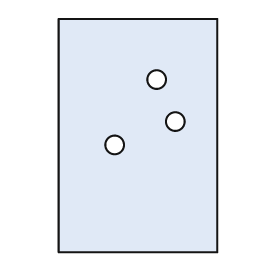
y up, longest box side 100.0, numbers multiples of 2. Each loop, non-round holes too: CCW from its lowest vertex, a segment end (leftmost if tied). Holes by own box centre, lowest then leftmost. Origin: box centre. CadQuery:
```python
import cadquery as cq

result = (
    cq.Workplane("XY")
    .moveTo(-34.0, -50.0)
    .lineTo(34.0, -50.0)
    .lineTo(34.0, 50.0)
    .lineTo(-34.0, 50.0)
    .close()
    .moveTo(-10.0, -4.0)
    .circle(4.0)
    .moveTo(16.0, 6.0)
    .circle(4.0)
    .moveTo(8.0, 24.0)
    .circle(4.0)
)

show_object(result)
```